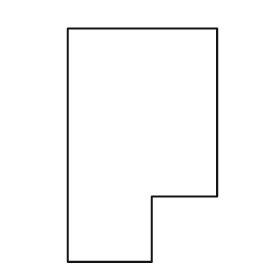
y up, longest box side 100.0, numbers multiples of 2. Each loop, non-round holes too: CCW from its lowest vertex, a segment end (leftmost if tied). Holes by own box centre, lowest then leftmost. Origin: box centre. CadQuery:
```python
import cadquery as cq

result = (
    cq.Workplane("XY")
    .moveTo(-32.0, -50.0)
    .lineTo(4.0, -50.0)
    .lineTo(4.0, -22.0)
    .lineTo(32.0, -22.0)
    .lineTo(32.0, 50.0)
    .lineTo(-32.0, 50.0)
    .close()
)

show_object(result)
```